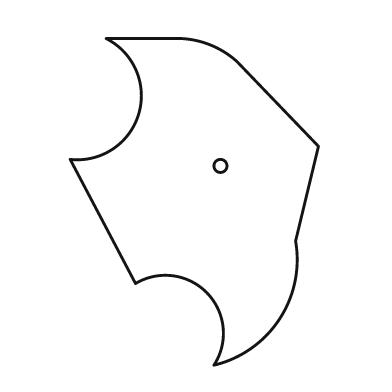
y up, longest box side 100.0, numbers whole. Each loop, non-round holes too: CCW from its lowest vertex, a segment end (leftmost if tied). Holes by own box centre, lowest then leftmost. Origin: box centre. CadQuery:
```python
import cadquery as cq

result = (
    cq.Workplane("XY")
    .moveTo(6.0, -50.0)
    .threePointArc((26.0, -36.0), (31.0, -12.0))
    .lineTo(38.0, 17.0)
    .lineTo(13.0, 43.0)
    .threePointArc((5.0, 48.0), (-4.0, 50.0))
    .lineTo(-27.0, 50.0)
    .threePointArc((-17.0, 27.0), (-38.0, 13.0))
    .lineTo(-18.0, -25.0)
    .threePointArc((4.0, -28.0), (6.0, -50.0))
    .close()
    .moveTo(8.0, 11.0)
    .circle(2.0)
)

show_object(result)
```